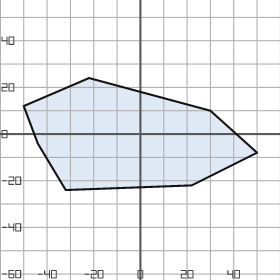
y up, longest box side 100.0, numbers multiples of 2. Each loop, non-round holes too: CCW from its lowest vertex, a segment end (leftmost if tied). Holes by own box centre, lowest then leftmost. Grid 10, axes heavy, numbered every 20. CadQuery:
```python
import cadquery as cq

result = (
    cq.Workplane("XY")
    .moveTo(-32.0, -24.0)
    .lineTo(22.0, -22.0)
    .lineTo(50.0, -8.0)
    .lineTo(30.0, 10.0)
    .lineTo(-22.0, 24.0)
    .lineTo(-50.0, 12.0)
    .lineTo(-44.0, -4.0)
    .close()
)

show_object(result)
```